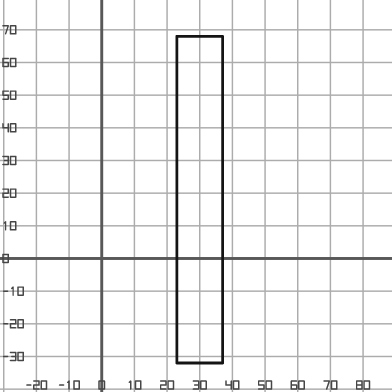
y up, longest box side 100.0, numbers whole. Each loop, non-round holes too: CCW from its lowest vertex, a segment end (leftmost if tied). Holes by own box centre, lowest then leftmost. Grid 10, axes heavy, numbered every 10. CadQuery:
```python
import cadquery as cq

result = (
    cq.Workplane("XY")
    .moveTo(23.0, -32.0)
    .lineTo(37.0, -32.0)
    .lineTo(37.0, 68.0)
    .lineTo(23.0, 68.0)
    .close()
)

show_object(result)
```